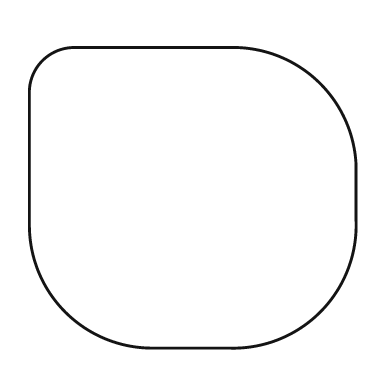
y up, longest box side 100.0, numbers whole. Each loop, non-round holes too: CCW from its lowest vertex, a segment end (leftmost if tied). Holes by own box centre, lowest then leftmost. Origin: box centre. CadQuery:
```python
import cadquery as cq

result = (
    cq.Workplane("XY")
    .moveTo(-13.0, -46.0)
    .lineTo(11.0, -46.0)
    .threePointArc((39.0, -35.0), (50.0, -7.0))
    .lineTo(50.0, 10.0)
    .threePointArc((39.0, 35.0), (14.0, 46.0))
    .lineTo(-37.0, 46.0)
    .threePointArc((-46.0, 42.0), (-50.0, 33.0))
    .lineTo(-50.0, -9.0)
    .threePointArc((-39.0, -35.0), (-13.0, -46.0))
    .close()
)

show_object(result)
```